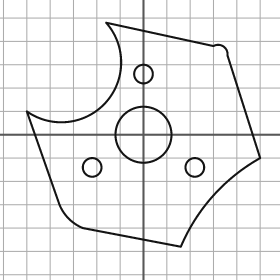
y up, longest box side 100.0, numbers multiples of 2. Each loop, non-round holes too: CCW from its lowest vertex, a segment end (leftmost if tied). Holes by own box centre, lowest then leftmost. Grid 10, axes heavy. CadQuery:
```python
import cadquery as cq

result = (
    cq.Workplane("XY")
    .moveTo(16.0, -48.0)
    .threePointArc((30.0, -26.0), (50.0, -10.0))
    .lineTo(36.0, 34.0)
    .threePointArc((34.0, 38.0), (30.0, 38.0))
    .lineTo(-16.0, 48.0)
    .threePointArc((-16.0, 14.0), (-50.0, 10.0))
    .lineTo(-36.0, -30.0)
    .threePointArc((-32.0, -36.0), (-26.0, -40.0))
    .close()
    .moveTo(-22.0, -14.0)
    .circle(4.0)
    .moveTo(22.0, -14.0)
    .circle(4.0)
    .moveTo(0.0, 0.0)
    .circle(12.0)
    .moveTo(0.0, 26.0)
    .circle(4.0)
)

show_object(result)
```